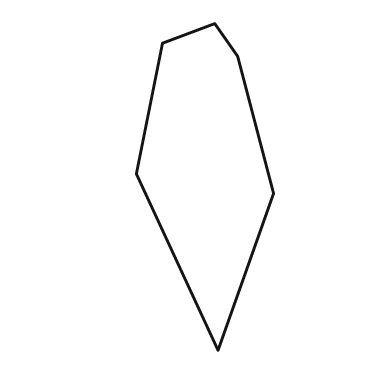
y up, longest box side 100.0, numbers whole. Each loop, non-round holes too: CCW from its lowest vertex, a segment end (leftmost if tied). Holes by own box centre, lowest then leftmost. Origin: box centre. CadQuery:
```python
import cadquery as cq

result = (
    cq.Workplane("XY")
    .moveTo(4.0, -50.0)
    .lineTo(21.0, -2.0)
    .lineTo(10.0, 40.0)
    .lineTo(3.0, 50.0)
    .lineTo(-13.0, 44.0)
    .lineTo(-21.0, 4.0)
    .close()
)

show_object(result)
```